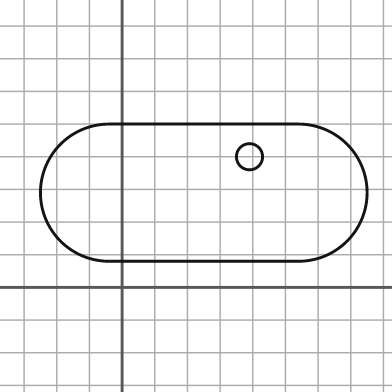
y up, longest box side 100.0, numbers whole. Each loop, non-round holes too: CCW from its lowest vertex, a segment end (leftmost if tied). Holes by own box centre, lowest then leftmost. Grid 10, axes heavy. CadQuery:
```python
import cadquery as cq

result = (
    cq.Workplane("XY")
    .moveTo(-4.0, 8.0)
    .lineTo(54.0, 8.0)
    .threePointArc((75.0, 29.0), (54.0, 50.0))
    .lineTo(-4.0, 50.0)
    .threePointArc((-25.0, 29.0), (-4.0, 8.0))
    .close()
    .moveTo(39.0, 40.0)
    .circle(4.0)
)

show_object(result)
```